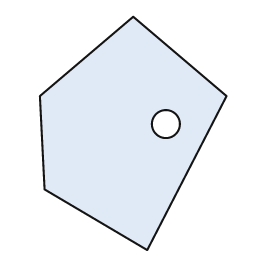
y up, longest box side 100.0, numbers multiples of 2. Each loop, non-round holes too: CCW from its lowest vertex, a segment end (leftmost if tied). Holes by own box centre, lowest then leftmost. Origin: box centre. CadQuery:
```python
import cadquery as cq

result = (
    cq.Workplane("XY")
    .moveTo(6.0, -50.0)
    .lineTo(40.0, 16.0)
    .lineTo(0.0, 50.0)
    .lineTo(-40.0, 16.0)
    .lineTo(-38.0, -24.0)
    .close()
    .moveTo(14.0, 4.0)
    .circle(6.0)
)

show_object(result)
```